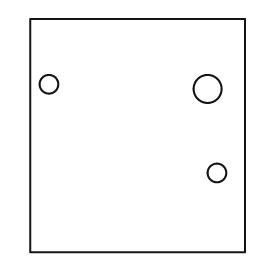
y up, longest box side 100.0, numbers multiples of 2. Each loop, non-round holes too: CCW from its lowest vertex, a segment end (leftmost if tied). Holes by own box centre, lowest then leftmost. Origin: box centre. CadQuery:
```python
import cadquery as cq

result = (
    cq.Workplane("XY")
    .moveTo(-46.0, -50.0)
    .lineTo(46.0, -50.0)
    .lineTo(46.0, 50.0)
    .lineTo(-46.0, 50.0)
    .close()
    .moveTo(34.0, -16.0)
    .circle(4.0)
    .moveTo(30.0, 20.0)
    .circle(6.0)
    .moveTo(-38.0, 22.0)
    .circle(4.0)
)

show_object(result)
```